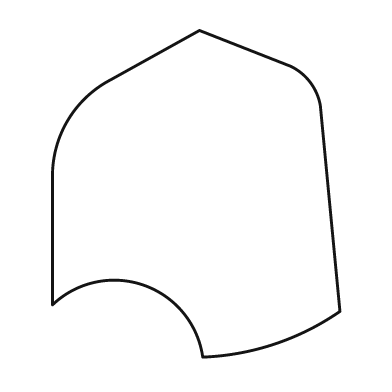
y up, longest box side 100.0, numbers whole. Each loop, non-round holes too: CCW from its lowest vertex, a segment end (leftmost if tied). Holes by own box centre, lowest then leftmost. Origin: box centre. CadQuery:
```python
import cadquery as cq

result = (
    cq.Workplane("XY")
    .moveTo(2.0, -50.0)
    .threePointArc((24.0, -46.0), (44.0, -36.0))
    .lineTo(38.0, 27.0)
    .threePointArc((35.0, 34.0), (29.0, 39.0))
    .lineTo(1.0, 50.0)
    .lineTo(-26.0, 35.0)
    .threePointArc((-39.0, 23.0), (-44.0, 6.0))
    .lineTo(-44.0, -34.0)
    .threePointArc((-16.0, -28.0), (2.0, -50.0))
    .close()
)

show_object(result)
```